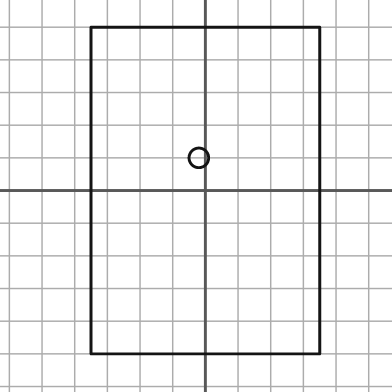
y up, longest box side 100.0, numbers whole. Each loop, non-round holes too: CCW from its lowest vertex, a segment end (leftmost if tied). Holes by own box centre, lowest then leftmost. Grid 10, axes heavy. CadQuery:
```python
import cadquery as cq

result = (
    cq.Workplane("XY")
    .moveTo(-35.0, -50.0)
    .lineTo(35.0, -50.0)
    .lineTo(35.0, 50.0)
    .lineTo(-35.0, 50.0)
    .close()
    .moveTo(-2.0, 10.0)
    .circle(3.0)
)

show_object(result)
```